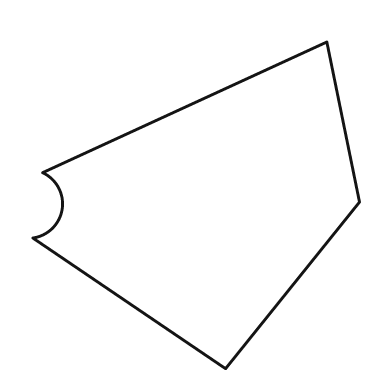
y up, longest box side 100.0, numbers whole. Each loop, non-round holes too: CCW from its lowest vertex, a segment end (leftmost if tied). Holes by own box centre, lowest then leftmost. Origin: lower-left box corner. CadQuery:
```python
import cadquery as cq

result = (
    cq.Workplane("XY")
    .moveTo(59.0, 0.0)
    .lineTo(100.0, 51.0)
    .lineTo(90.0, 100.0)
    .lineTo(3.0, 60.0)
    .threePointArc((9.0, 49.0), (0.0, 40.0))
    .close()
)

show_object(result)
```